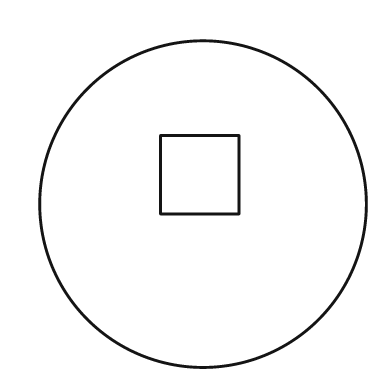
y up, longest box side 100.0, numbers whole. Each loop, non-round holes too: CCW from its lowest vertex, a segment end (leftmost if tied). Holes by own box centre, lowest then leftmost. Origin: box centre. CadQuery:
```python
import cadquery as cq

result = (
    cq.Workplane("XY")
    .moveTo(0.0, 0.0)
    .circle(50.0)
    .moveTo(-13.0, -3.0)
    .lineTo(11.0, -3.0)
    .lineTo(11.0, 21.0)
    .lineTo(-13.0, 21.0)
    .close()
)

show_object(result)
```